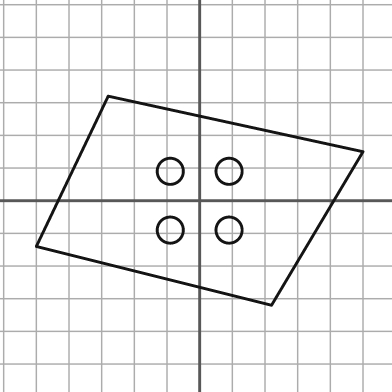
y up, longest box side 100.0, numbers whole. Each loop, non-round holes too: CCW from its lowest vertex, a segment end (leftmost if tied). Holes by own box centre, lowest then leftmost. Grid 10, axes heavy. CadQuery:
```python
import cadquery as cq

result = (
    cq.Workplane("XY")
    .moveTo(22.0, -32.0)
    .lineTo(50.0, 15.0)
    .lineTo(-28.0, 32.0)
    .lineTo(-50.0, -14.0)
    .close()
    .moveTo(-9.0, -9.0)
    .circle(4.0)
    .moveTo(9.0, -9.0)
    .circle(4.0)
    .moveTo(-9.0, 9.0)
    .circle(4.0)
    .moveTo(9.0, 9.0)
    .circle(4.0)
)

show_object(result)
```